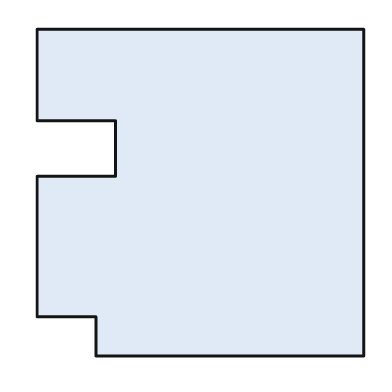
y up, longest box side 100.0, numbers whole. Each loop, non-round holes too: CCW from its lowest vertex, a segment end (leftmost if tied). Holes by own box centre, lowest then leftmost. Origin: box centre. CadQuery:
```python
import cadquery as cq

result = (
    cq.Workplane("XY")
    .moveTo(-32.0, -50.0)
    .lineTo(50.0, -50.0)
    .lineTo(50.0, 50.0)
    .lineTo(-50.0, 50.0)
    .lineTo(-50.0, 22.0)
    .lineTo(-26.0, 22.0)
    .lineTo(-26.0, 5.0)
    .lineTo(-50.0, 5.0)
    .lineTo(-50.0, -38.0)
    .lineTo(-32.0, -38.0)
    .close()
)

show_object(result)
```